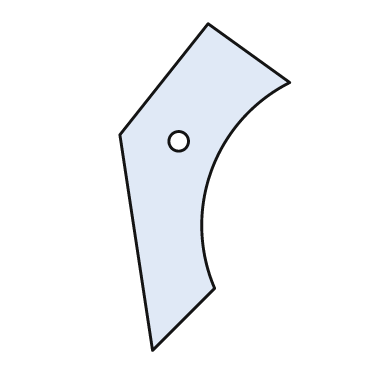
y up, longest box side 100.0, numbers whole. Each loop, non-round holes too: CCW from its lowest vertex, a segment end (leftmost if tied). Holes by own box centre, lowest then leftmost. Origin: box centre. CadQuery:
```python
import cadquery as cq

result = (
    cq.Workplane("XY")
    .moveTo(-16.0, -50.0)
    .lineTo(3.0, -31.0)
    .threePointArc((2.0, 5.0), (26.0, 32.0))
    .lineTo(1.0, 50.0)
    .lineTo(-26.0, 16.0)
    .close()
    .moveTo(-8.0, 14.0)
    .circle(3.0)
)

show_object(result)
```